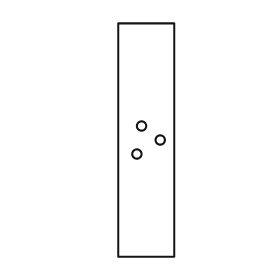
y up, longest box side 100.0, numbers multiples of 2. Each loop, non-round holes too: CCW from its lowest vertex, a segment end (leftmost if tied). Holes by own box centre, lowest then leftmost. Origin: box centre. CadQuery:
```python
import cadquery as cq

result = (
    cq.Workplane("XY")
    .moveTo(-12.0, -50.0)
    .lineTo(12.0, -50.0)
    .lineTo(12.0, 50.0)
    .lineTo(-12.0, 50.0)
    .close()
    .moveTo(-4.0, -6.0)
    .circle(2.0)
    .moveTo(6.0, 0.0)
    .circle(2.0)
    .moveTo(-2.0, 6.0)
    .circle(2.0)
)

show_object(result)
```